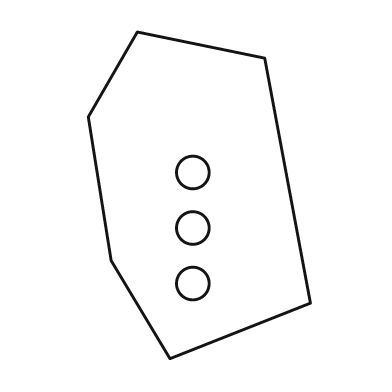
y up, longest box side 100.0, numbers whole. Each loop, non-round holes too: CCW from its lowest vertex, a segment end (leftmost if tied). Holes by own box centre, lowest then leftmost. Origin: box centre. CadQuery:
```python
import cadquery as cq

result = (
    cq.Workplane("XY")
    .moveTo(-9.0, -50.0)
    .lineTo(34.0, -33.0)
    .lineTo(20.0, 42.0)
    .lineTo(-19.0, 50.0)
    .lineTo(-34.0, 24.0)
    .lineTo(-27.0, -20.0)
    .close()
    .moveTo(-2.0, -27.0)
    .circle(5.0)
    .moveTo(-2.0, -10.0)
    .circle(5.0)
    .moveTo(-2.0, 7.0)
    .circle(5.0)
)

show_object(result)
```